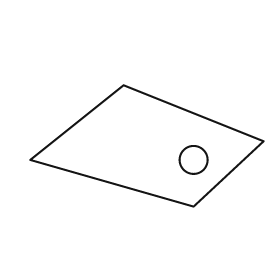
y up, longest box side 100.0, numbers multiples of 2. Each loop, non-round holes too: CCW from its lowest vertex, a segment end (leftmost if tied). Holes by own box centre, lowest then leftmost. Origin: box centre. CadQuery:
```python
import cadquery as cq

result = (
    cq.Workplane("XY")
    .moveTo(20.0, -26.0)
    .lineTo(50.0, 2.0)
    .lineTo(-10.0, 26.0)
    .lineTo(-50.0, -6.0)
    .close()
    .moveTo(20.0, -6.0)
    .circle(6.0)
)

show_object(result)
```